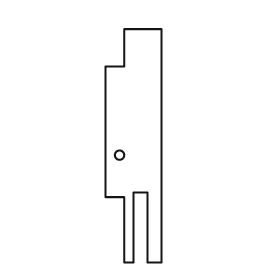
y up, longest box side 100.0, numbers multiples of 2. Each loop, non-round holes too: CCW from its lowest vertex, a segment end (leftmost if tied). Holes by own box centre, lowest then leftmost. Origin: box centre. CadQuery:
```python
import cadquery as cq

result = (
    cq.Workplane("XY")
    .moveTo(-4.0, -50.0)
    .lineTo(0.0, -50.0)
    .lineTo(0.0, -20.0)
    .lineTo(6.0, -20.0)
    .lineTo(6.0, -50.0)
    .lineTo(12.0, -50.0)
    .lineTo(12.0, 50.0)
    .lineTo(-4.0, 50.0)
    .lineTo(-4.0, 34.0)
    .lineTo(-12.0, 34.0)
    .lineTo(-12.0, -22.0)
    .lineTo(-4.0, -22.0)
    .close()
    .moveTo(-6.0, -4.0)
    .circle(2.0)
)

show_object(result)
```